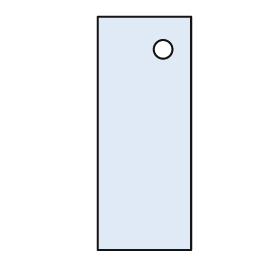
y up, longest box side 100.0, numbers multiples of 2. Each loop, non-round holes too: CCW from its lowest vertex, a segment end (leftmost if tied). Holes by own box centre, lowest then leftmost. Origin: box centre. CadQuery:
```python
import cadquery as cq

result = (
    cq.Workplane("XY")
    .moveTo(-20.0, -50.0)
    .lineTo(20.0, -50.0)
    .lineTo(20.0, 50.0)
    .lineTo(-20.0, 50.0)
    .close()
    .moveTo(8.0, 36.0)
    .circle(4.0)
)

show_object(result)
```